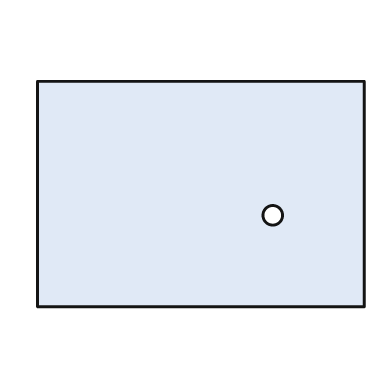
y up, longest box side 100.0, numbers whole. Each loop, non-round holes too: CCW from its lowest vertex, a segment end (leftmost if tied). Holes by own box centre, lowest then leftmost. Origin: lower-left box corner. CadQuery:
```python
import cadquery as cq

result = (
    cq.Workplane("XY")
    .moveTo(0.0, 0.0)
    .lineTo(100.0, 0.0)
    .lineTo(100.0, 69.0)
    .lineTo(0.0, 69.0)
    .close()
    .moveTo(72.0, 28.0)
    .circle(3.0)
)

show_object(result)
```